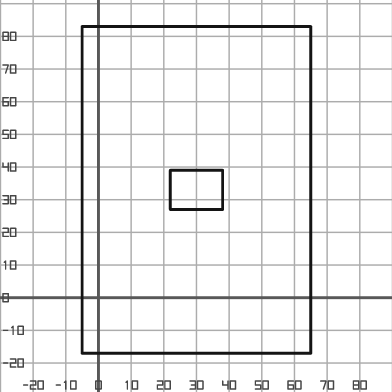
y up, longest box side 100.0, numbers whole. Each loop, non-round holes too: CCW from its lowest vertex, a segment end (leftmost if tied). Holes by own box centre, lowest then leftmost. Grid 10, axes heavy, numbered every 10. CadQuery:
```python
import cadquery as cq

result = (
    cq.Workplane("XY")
    .moveTo(-5.0, -17.0)
    .lineTo(65.0, -17.0)
    .lineTo(65.0, 83.0)
    .lineTo(-5.0, 83.0)
    .close()
    .moveTo(22.0, 27.0)
    .lineTo(38.0, 27.0)
    .lineTo(38.0, 39.0)
    .lineTo(22.0, 39.0)
    .close()
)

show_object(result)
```